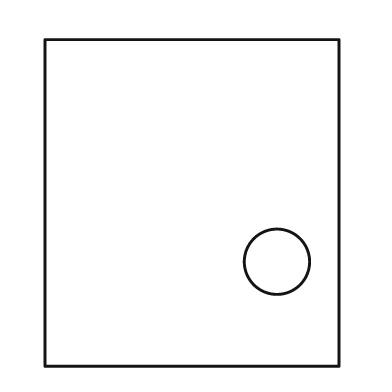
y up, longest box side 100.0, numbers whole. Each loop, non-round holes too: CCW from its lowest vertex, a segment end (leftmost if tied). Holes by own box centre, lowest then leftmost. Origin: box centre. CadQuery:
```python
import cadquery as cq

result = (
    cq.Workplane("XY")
    .moveTo(-45.0, -50.0)
    .lineTo(45.0, -50.0)
    .lineTo(45.0, 50.0)
    .lineTo(-45.0, 50.0)
    .close()
    .moveTo(26.0, -18.0)
    .circle(10.0)
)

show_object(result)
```